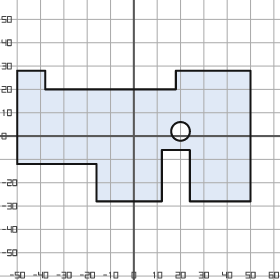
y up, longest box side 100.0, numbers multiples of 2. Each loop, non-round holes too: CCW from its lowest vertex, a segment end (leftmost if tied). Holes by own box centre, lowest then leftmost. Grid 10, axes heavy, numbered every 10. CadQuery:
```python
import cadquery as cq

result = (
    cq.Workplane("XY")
    .moveTo(-16.0, -28.0)
    .lineTo(12.0, -28.0)
    .lineTo(12.0, -6.0)
    .lineTo(24.0, -6.0)
    .lineTo(24.0, -28.0)
    .lineTo(50.0, -28.0)
    .lineTo(50.0, 28.0)
    .lineTo(18.0, 28.0)
    .lineTo(18.0, 20.0)
    .lineTo(-38.0, 20.0)
    .lineTo(-38.0, 28.0)
    .lineTo(-50.0, 28.0)
    .lineTo(-50.0, -12.0)
    .lineTo(-16.0, -12.0)
    .close()
    .moveTo(20.0, 2.0)
    .circle(4.0)
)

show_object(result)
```